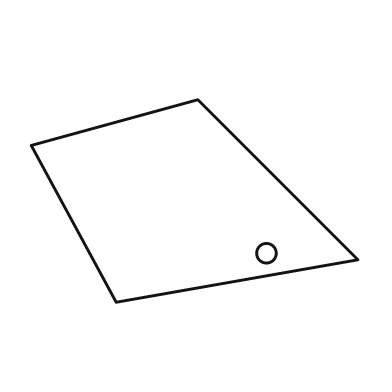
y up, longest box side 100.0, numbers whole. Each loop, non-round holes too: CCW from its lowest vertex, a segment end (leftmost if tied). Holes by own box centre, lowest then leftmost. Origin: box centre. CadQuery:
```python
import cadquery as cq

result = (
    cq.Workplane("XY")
    .moveTo(-24.0, -31.0)
    .lineTo(50.0, -18.0)
    .lineTo(1.0, 31.0)
    .lineTo(-50.0, 17.0)
    .close()
    .moveTo(22.0, -16.0)
    .circle(3.0)
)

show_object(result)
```